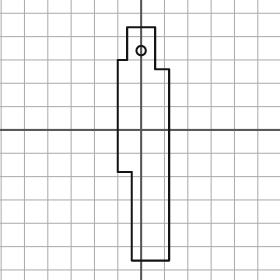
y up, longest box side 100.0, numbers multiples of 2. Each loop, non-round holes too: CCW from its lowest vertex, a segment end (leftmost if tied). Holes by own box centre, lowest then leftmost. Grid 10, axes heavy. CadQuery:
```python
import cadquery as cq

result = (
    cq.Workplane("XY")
    .moveTo(-4.0, -56.0)
    .lineTo(12.0, -56.0)
    .lineTo(12.0, 26.0)
    .lineTo(6.0, 26.0)
    .lineTo(6.0, 44.0)
    .lineTo(-6.0, 44.0)
    .lineTo(-6.0, 30.0)
    .lineTo(-10.0, 30.0)
    .lineTo(-10.0, -18.0)
    .lineTo(-4.0, -18.0)
    .close()
    .moveTo(0.0, 34.0)
    .circle(2.0)
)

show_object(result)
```